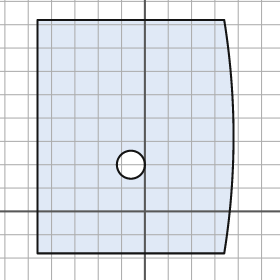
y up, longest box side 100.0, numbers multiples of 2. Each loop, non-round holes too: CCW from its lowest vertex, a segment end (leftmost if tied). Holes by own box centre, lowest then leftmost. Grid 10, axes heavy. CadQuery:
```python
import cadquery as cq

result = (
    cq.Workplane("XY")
    .moveTo(-46.0, -18.0)
    .lineTo(34.0, -18.0)
    .threePointArc((38.0, 32.0), (34.0, 82.0))
    .lineTo(-46.0, 82.0)
    .close()
    .moveTo(-6.0, 20.0)
    .circle(6.0)
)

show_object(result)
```